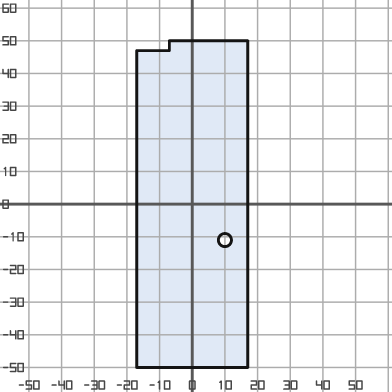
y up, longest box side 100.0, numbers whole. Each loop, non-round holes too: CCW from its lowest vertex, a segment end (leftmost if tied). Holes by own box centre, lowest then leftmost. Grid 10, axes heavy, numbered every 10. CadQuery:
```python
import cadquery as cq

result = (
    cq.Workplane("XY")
    .moveTo(-17.0, -50.0)
    .lineTo(17.0, -50.0)
    .lineTo(17.0, 50.0)
    .lineTo(-7.0, 50.0)
    .lineTo(-7.0, 47.0)
    .lineTo(-17.0, 47.0)
    .close()
    .moveTo(10.0, -11.0)
    .circle(2.0)
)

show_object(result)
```